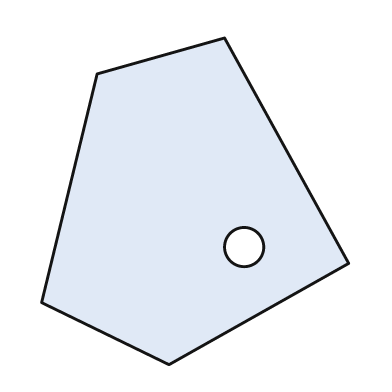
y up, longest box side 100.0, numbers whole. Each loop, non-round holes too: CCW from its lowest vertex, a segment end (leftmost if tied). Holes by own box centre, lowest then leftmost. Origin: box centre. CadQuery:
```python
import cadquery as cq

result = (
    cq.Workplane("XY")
    .moveTo(-8.0, -50.0)
    .lineTo(47.0, -19.0)
    .lineTo(9.0, 50.0)
    .lineTo(-30.0, 39.0)
    .lineTo(-47.0, -31.0)
    .close()
    .moveTo(15.0, -14.0)
    .circle(6.0)
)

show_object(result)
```